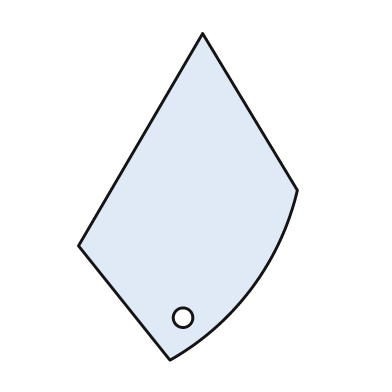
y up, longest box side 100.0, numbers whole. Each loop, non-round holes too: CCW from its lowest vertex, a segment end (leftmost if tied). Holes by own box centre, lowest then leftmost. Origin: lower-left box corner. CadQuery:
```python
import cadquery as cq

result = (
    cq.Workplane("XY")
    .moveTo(28.0, 0.0)
    .threePointArc((53.0, 22.0), (67.0, 52.0))
    .lineTo(38.0, 100.0)
    .lineTo(0.0, 35.0)
    .close()
    .moveTo(32.0, 13.0)
    .circle(3.0)
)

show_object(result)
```